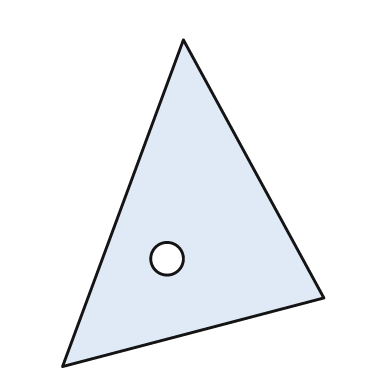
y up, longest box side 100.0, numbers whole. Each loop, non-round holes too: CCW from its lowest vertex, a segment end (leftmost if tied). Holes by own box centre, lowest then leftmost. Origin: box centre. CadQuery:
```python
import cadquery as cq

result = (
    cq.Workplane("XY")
    .moveTo(-40.0, -50.0)
    .lineTo(40.0, -29.0)
    .lineTo(-3.0, 50.0)
    .close()
    .moveTo(-8.0, -17.0)
    .circle(5.0)
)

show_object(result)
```